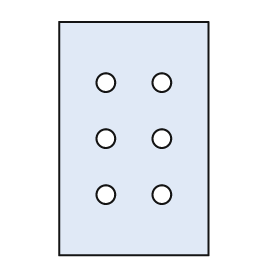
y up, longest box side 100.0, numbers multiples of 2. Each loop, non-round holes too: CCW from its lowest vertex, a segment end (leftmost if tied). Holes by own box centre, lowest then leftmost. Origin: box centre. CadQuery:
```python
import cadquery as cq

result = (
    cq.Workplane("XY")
    .moveTo(-32.0, -50.0)
    .lineTo(32.0, -50.0)
    .lineTo(32.0, 50.0)
    .lineTo(-32.0, 50.0)
    .close()
    .moveTo(-12.0, -24.0)
    .circle(4.0)
    .moveTo(12.0, -24.0)
    .circle(4.0)
    .moveTo(-12.0, 0.0)
    .circle(4.0)
    .moveTo(12.0, 0.0)
    .circle(4.0)
    .moveTo(-12.0, 24.0)
    .circle(4.0)
    .moveTo(12.0, 24.0)
    .circle(4.0)
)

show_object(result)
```